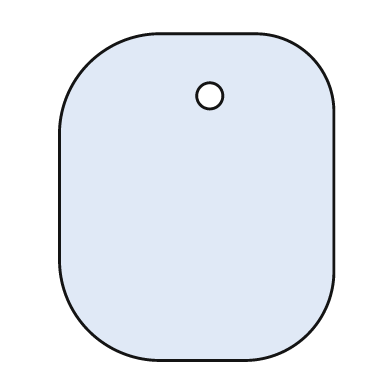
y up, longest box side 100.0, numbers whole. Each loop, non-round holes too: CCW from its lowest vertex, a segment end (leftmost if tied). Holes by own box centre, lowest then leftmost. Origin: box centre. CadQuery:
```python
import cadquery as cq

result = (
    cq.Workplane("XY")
    .moveTo(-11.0, -50.0)
    .lineTo(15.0, -50.0)
    .threePointArc((34.0, -42.0), (42.0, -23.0))
    .lineTo(42.0, 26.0)
    .threePointArc((35.0, 43.0), (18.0, 50.0))
    .lineTo(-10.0, 50.0)
    .threePointArc((-33.0, 41.0), (-42.0, 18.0))
    .lineTo(-42.0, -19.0)
    .threePointArc((-33.0, -41.0), (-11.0, -50.0))
    .close()
    .moveTo(4.0, 31.0)
    .circle(4.0)
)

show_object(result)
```